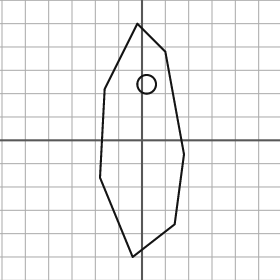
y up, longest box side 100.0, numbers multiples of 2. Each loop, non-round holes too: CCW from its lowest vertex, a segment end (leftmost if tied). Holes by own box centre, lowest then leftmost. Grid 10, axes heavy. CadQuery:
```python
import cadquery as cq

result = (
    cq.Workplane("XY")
    .moveTo(-4.0, -50.0)
    .lineTo(14.0, -36.0)
    .lineTo(18.0, -6.0)
    .lineTo(10.0, 38.0)
    .lineTo(-2.0, 50.0)
    .lineTo(-16.0, 22.0)
    .lineTo(-18.0, -16.0)
    .close()
    .moveTo(2.0, 24.0)
    .circle(4.0)
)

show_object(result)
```